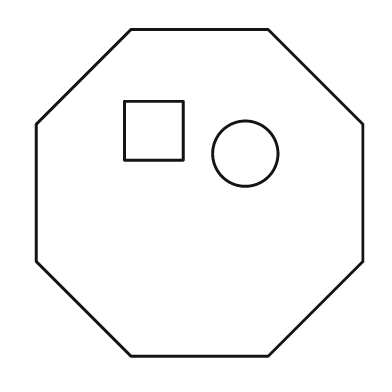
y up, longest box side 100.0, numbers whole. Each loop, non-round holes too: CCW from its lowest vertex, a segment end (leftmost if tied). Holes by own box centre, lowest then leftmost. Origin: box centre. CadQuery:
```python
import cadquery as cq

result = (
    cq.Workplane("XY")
    .moveTo(-21.0, -50.0)
    .lineTo(21.0, -50.0)
    .lineTo(50.0, -21.0)
    .lineTo(50.0, 21.0)
    .lineTo(21.0, 50.0)
    .lineTo(-21.0, 50.0)
    .lineTo(-50.0, 21.0)
    .lineTo(-50.0, -21.0)
    .close()
    .moveTo(14.0, 12.0)
    .circle(10.0)
    .moveTo(-23.0, 10.0)
    .lineTo(-5.0, 10.0)
    .lineTo(-5.0, 28.0)
    .lineTo(-23.0, 28.0)
    .close()
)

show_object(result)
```